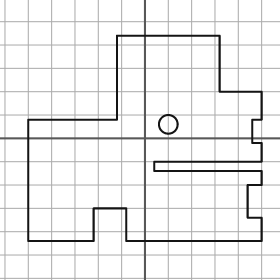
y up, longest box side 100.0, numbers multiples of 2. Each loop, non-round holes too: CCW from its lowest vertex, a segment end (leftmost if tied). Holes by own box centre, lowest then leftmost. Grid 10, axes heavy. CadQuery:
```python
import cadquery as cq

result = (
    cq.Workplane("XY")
    .moveTo(-50.0, -44.0)
    .lineTo(-22.0, -44.0)
    .lineTo(-22.0, -30.0)
    .lineTo(-8.0, -30.0)
    .lineTo(-8.0, -44.0)
    .lineTo(50.0, -44.0)
    .lineTo(50.0, -34.0)
    .lineTo(44.0, -34.0)
    .lineTo(44.0, -20.0)
    .lineTo(50.0, -20.0)
    .lineTo(50.0, -14.0)
    .lineTo(4.0, -14.0)
    .lineTo(4.0, -10.0)
    .lineTo(50.0, -10.0)
    .lineTo(50.0, -2.0)
    .lineTo(46.0, -2.0)
    .lineTo(46.0, 8.0)
    .lineTo(50.0, 8.0)
    .lineTo(50.0, 20.0)
    .lineTo(32.0, 20.0)
    .lineTo(32.0, 44.0)
    .lineTo(-12.0, 44.0)
    .lineTo(-12.0, 8.0)
    .lineTo(-50.0, 8.0)
    .close()
    .moveTo(10.0, 6.0)
    .circle(4.0)
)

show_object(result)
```